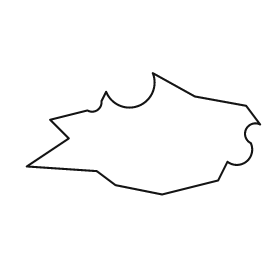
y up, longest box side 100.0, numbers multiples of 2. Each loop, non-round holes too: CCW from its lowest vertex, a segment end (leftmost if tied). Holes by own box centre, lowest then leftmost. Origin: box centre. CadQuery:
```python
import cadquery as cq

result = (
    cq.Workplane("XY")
    .moveTo(8.0, -26.0)
    .lineTo(32.0, -20.0)
    .lineTo(36.0, -12.0)
    .threePointArc((44.0, -12.0), (46.0, -4.0))
    .threePointArc((44.0, 2.0), (50.0, 4.0))
    .lineTo(44.0, 12.0)
    .lineTo(22.0, 16.0)
    .lineTo(4.0, 26.0)
    .threePointArc((-2.0, 12.0), (-16.0, 18.0))
    .lineTo(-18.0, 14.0)
    .threePointArc((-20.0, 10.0), (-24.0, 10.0))
    .lineTo(-40.0, 6.0)
    .lineTo(-32.0, -2.0)
    .lineTo(-50.0, -14.0)
    .lineTo(-20.0, -16.0)
    .lineTo(-12.0, -22.0)
    .close()
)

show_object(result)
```